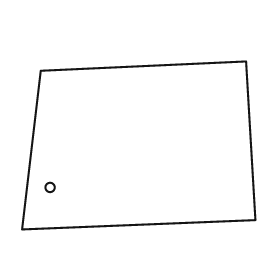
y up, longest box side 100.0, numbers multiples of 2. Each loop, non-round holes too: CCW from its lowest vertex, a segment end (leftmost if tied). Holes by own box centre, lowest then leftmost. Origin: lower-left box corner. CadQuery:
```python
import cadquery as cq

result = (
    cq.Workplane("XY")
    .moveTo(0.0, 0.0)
    .lineTo(100.0, 4.0)
    .lineTo(96.0, 72.0)
    .lineTo(8.0, 68.0)
    .close()
    .moveTo(12.0, 18.0)
    .circle(2.0)
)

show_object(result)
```